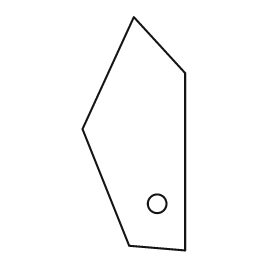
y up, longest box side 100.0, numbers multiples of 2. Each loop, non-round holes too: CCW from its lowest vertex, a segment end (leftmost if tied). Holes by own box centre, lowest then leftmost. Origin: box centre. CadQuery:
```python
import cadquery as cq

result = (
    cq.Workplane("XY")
    .moveTo(22.0, -50.0)
    .lineTo(22.0, 26.0)
    .lineTo(0.0, 50.0)
    .lineTo(-22.0, 2.0)
    .lineTo(-2.0, -48.0)
    .close()
    .moveTo(10.0, -30.0)
    .circle(4.0)
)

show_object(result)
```